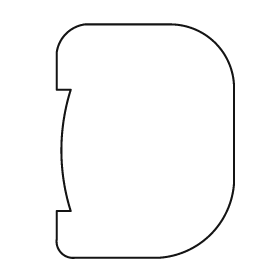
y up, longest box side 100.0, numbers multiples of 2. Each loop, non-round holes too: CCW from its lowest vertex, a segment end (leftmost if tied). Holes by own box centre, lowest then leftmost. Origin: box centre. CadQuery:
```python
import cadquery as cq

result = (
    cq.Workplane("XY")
    .moveTo(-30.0, -50.0)
    .lineTo(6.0, -50.0)
    .threePointArc((28.0, -40.0), (38.0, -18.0))
    .lineTo(38.0, 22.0)
    .threePointArc((30.0, 42.0), (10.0, 50.0))
    .lineTo(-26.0, 50.0)
    .threePointArc((-34.0, 46.0), (-38.0, 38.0))
    .lineTo(-38.0, 22.0)
    .lineTo(-32.0, 22.0)
    .threePointArc((-36.0, -4.0), (-32.0, -30.0))
    .lineTo(-38.0, -30.0)
    .lineTo(-38.0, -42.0)
    .threePointArc((-36.0, -48.0), (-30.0, -50.0))
    .close()
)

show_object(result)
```